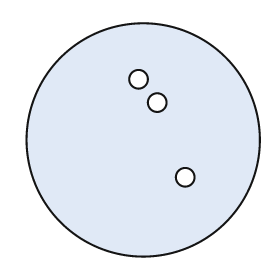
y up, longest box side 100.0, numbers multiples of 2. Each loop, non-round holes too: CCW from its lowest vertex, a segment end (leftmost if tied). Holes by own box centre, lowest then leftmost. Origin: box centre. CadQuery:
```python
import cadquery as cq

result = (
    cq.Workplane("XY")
    .moveTo(0.0, 0.0)
    .circle(50.0)
    .moveTo(18.0, -16.0)
    .circle(4.0)
    .moveTo(6.0, 16.0)
    .circle(4.0)
    .moveTo(-2.0, 26.0)
    .circle(4.0)
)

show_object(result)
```